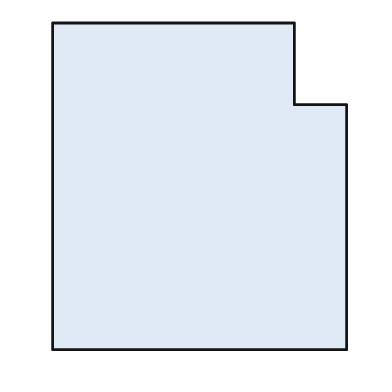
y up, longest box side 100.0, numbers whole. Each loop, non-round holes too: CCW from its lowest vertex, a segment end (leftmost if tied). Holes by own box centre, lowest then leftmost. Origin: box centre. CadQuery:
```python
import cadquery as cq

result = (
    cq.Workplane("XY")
    .moveTo(-45.0, -50.0)
    .lineTo(45.0, -50.0)
    .lineTo(45.0, 25.0)
    .lineTo(29.0, 25.0)
    .lineTo(29.0, 50.0)
    .lineTo(-45.0, 50.0)
    .close()
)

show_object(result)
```